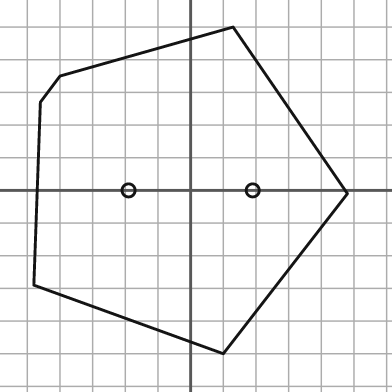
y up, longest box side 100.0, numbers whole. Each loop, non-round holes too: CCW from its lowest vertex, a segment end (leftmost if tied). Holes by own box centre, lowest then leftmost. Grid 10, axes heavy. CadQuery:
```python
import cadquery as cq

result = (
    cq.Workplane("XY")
    .moveTo(10.0, -50.0)
    .lineTo(48.0, -1.0)
    .lineTo(13.0, 50.0)
    .lineTo(-40.0, 35.0)
    .lineTo(-46.0, 27.0)
    .lineTo(-48.0, -29.0)
    .close()
    .moveTo(-19.0, 0.0)
    .circle(2.0)
    .moveTo(19.0, 0.0)
    .circle(2.0)
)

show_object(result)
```